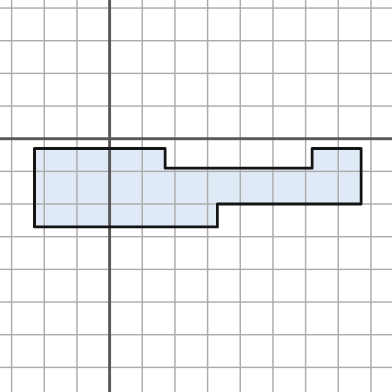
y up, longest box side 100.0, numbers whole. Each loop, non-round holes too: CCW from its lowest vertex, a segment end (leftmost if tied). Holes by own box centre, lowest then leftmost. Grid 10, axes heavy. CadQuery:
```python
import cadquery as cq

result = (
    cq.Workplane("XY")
    .moveTo(-23.0, -27.0)
    .lineTo(33.0, -27.0)
    .lineTo(33.0, -20.0)
    .lineTo(77.0, -20.0)
    .lineTo(77.0, -3.0)
    .lineTo(62.0, -3.0)
    .lineTo(62.0, -9.0)
    .lineTo(17.0, -9.0)
    .lineTo(17.0, -3.0)
    .lineTo(-23.0, -3.0)
    .close()
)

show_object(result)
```